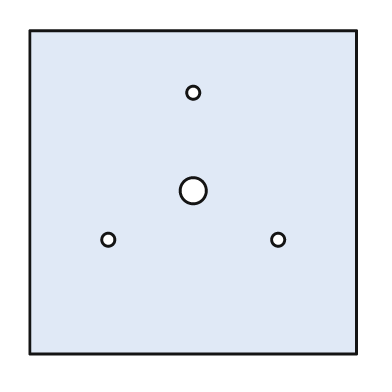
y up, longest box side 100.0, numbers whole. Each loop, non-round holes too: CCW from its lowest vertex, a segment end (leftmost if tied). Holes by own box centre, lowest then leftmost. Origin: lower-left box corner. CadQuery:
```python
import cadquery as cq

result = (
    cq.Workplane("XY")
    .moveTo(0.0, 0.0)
    .lineTo(100.0, 0.0)
    .lineTo(100.0, 99.0)
    .lineTo(0.0, 99.0)
    .close()
    .moveTo(24.0, 35.0)
    .circle(2.0)
    .moveTo(76.0, 35.0)
    .circle(2.0)
    .moveTo(50.0, 50.0)
    .circle(4.0)
    .moveTo(50.0, 80.0)
    .circle(2.0)
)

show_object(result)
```